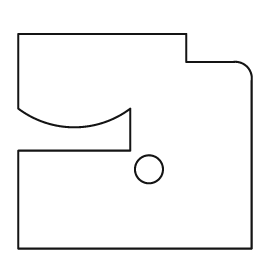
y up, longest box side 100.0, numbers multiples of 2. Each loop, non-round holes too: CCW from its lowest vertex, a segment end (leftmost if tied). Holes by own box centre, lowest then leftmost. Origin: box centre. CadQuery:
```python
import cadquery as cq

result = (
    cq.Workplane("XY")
    .moveTo(-50.0, -46.0)
    .lineTo(50.0, -46.0)
    .lineTo(50.0, 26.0)
    .threePointArc((48.0, 32.0), (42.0, 34.0))
    .lineTo(22.0, 34.0)
    .lineTo(22.0, 46.0)
    .lineTo(-50.0, 46.0)
    .lineTo(-50.0, 14.0)
    .threePointArc((-26.0, 6.0), (-2.0, 14.0))
    .lineTo(-2.0, -4.0)
    .lineTo(-50.0, -4.0)
    .close()
    .moveTo(6.0, -12.0)
    .circle(6.0)
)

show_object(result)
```